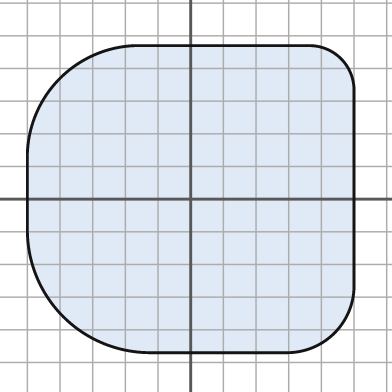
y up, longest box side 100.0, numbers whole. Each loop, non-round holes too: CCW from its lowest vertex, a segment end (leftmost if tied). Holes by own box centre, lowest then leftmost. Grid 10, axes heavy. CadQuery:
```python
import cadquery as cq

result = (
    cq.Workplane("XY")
    .moveTo(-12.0, -47.0)
    .lineTo(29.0, -47.0)
    .threePointArc((44.0, -41.0), (50.0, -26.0))
    .lineTo(50.0, 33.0)
    .threePointArc((46.0, 43.0), (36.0, 47.0))
    .lineTo(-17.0, 47.0)
    .threePointArc((-40.0, 37.0), (-50.0, 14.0))
    .lineTo(-50.0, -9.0)
    .threePointArc((-39.0, -36.0), (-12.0, -47.0))
    .close()
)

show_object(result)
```